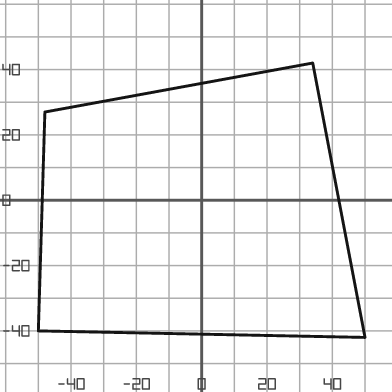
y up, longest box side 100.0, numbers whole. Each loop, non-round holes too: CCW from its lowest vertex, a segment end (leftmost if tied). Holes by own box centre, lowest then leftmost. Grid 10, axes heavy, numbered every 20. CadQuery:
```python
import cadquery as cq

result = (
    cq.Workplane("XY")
    .moveTo(50.0, -42.0)
    .lineTo(34.0, 42.0)
    .lineTo(-48.0, 27.0)
    .lineTo(-50.0, -40.0)
    .close()
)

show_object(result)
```